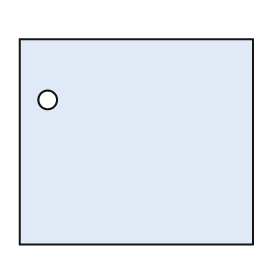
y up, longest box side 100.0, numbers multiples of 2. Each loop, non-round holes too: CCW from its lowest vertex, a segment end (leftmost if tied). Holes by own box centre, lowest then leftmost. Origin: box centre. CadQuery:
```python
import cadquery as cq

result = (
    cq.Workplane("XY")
    .moveTo(-50.0, -44.0)
    .lineTo(50.0, -44.0)
    .lineTo(50.0, 44.0)
    .lineTo(-50.0, 44.0)
    .close()
    .moveTo(-38.0, 18.0)
    .circle(4.0)
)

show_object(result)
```